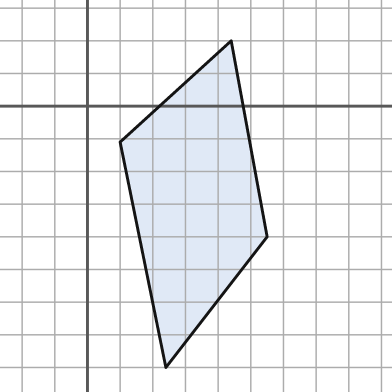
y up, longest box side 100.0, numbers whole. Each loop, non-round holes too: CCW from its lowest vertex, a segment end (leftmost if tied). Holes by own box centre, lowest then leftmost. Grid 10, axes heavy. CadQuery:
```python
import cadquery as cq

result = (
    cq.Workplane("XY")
    .moveTo(24.0, -80.0)
    .lineTo(55.0, -40.0)
    .lineTo(44.0, 20.0)
    .lineTo(10.0, -11.0)
    .close()
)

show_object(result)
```